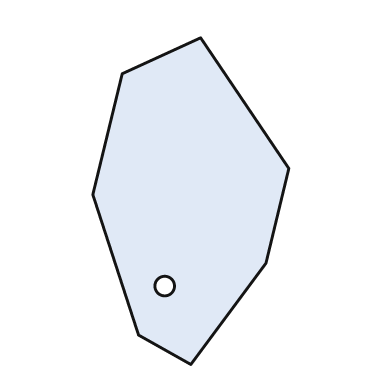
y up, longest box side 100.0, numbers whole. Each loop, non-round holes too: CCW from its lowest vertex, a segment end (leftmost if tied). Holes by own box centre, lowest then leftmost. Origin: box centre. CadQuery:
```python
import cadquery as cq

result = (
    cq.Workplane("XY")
    .moveTo(0.0, -50.0)
    .lineTo(23.0, -19.0)
    .lineTo(30.0, 10.0)
    .lineTo(3.0, 50.0)
    .lineTo(-21.0, 39.0)
    .lineTo(-30.0, 2.0)
    .lineTo(-16.0, -41.0)
    .close()
    .moveTo(-8.0, -26.0)
    .circle(3.0)
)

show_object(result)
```